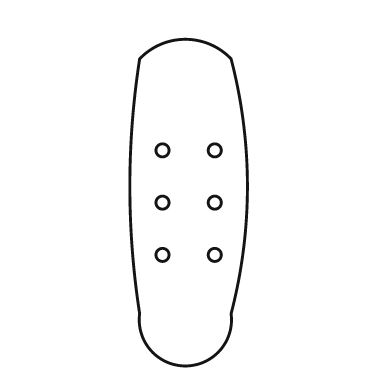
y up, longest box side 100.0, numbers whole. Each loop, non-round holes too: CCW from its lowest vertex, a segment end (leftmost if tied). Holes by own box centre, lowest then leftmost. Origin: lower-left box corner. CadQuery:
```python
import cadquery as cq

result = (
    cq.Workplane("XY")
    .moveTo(3.0, 16.0)
    .threePointArc((17.0, 0.0), (31.0, 16.0))
    .threePointArc((36.0, 55.0), (31.0, 94.0))
    .threePointArc((17.0, 100.0), (3.0, 94.0))
    .threePointArc((0.0, 55.0), (3.0, 16.0))
    .close()
    .moveTo(10.0, 34.0)
    .circle(2.0)
    .moveTo(26.0, 34.0)
    .circle(2.0)
    .moveTo(10.0, 50.0)
    .circle(2.0)
    .moveTo(26.0, 50.0)
    .circle(2.0)
    .moveTo(10.0, 66.0)
    .circle(2.0)
    .moveTo(26.0, 66.0)
    .circle(2.0)
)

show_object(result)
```